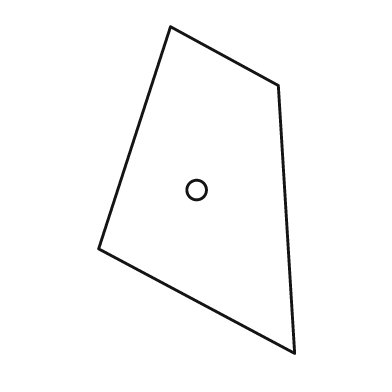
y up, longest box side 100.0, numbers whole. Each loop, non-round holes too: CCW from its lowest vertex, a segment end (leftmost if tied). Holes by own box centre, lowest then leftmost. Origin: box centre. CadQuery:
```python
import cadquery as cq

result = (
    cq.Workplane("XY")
    .moveTo(30.0, -50.0)
    .lineTo(25.0, 32.0)
    .lineTo(-8.0, 50.0)
    .lineTo(-30.0, -18.0)
    .close()
    .moveTo(0.0, 0.0)
    .circle(3.0)
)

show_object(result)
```